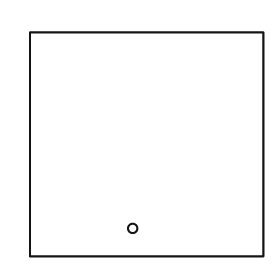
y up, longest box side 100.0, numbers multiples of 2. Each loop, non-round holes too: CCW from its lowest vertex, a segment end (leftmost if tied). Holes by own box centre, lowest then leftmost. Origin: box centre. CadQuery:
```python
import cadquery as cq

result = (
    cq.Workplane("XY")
    .moveTo(-50.0, -48.0)
    .lineTo(50.0, -48.0)
    .lineTo(50.0, 48.0)
    .lineTo(-50.0, 48.0)
    .close()
    .moveTo(-6.0, -36.0)
    .circle(2.0)
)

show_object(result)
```